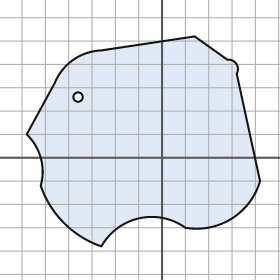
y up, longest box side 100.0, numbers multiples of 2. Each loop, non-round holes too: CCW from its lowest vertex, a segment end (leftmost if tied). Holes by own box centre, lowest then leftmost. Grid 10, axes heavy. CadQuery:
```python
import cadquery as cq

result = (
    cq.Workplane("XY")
    .moveTo(-26.0, -38.0)
    .threePointArc((-10.0, -26.0), (10.0, -30.0))
    .threePointArc((30.0, -26.0), (42.0, -10.0))
    .lineTo(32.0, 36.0)
    .threePointArc((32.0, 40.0), (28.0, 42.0))
    .lineTo(14.0, 52.0)
    .lineTo(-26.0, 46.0)
    .threePointArc((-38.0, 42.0), (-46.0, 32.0))
    .lineTo(-58.0, 10.0)
    .threePointArc((-52.0, 0.0), (-52.0, -12.0))
    .threePointArc((-42.0, -28.0), (-26.0, -38.0))
    .close()
    .moveTo(-36.0, 26.0)
    .circle(2.0)
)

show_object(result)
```